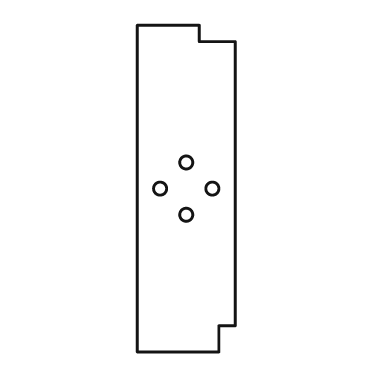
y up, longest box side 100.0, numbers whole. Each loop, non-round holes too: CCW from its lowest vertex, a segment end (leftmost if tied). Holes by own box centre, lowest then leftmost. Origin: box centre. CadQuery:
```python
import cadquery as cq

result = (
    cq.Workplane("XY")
    .moveTo(-15.0, -50.0)
    .lineTo(10.0, -50.0)
    .lineTo(10.0, -42.0)
    .lineTo(15.0, -42.0)
    .lineTo(15.0, 45.0)
    .lineTo(4.0, 45.0)
    .lineTo(4.0, 50.0)
    .lineTo(-15.0, 50.0)
    .close()
    .moveTo(0.0, -8.0)
    .circle(2.0)
    .moveTo(-8.0, 0.0)
    .circle(2.0)
    .moveTo(8.0, 0.0)
    .circle(2.0)
    .moveTo(0.0, 8.0)
    .circle(2.0)
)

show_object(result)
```